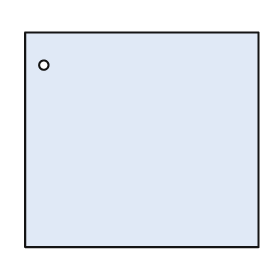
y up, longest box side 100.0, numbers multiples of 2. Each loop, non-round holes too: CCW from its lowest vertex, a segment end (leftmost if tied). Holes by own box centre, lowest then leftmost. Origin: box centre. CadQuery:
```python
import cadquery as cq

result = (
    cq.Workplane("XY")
    .moveTo(-50.0, -46.0)
    .lineTo(50.0, -46.0)
    .lineTo(50.0, 46.0)
    .lineTo(-50.0, 46.0)
    .close()
    .moveTo(-42.0, 32.0)
    .circle(2.0)
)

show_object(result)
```